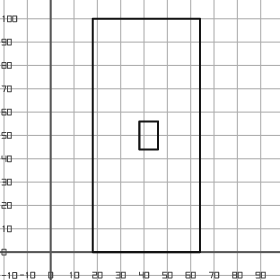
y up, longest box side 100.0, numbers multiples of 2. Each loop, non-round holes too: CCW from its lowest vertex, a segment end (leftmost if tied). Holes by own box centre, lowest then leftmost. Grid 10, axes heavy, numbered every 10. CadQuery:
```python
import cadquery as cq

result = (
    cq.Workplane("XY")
    .moveTo(18.0, 0.0)
    .lineTo(64.0, 0.0)
    .lineTo(64.0, 100.0)
    .lineTo(18.0, 100.0)
    .close()
    .moveTo(38.0, 44.0)
    .lineTo(46.0, 44.0)
    .lineTo(46.0, 56.0)
    .lineTo(38.0, 56.0)
    .close()
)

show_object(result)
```